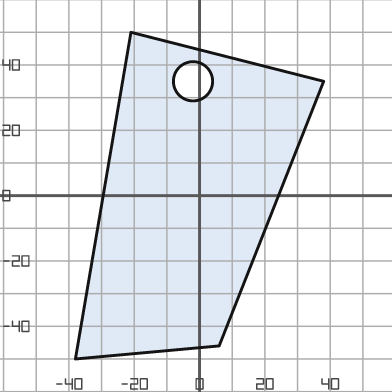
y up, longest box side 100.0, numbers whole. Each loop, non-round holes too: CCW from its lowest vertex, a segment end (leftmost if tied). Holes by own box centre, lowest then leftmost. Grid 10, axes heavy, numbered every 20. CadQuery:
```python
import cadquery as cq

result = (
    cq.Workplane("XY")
    .moveTo(-38.0, -50.0)
    .lineTo(6.0, -46.0)
    .lineTo(38.0, 35.0)
    .lineTo(-21.0, 50.0)
    .close()
    .moveTo(-2.0, 35.0)
    .circle(6.0)
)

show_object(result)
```